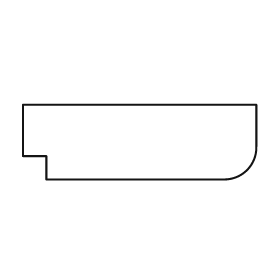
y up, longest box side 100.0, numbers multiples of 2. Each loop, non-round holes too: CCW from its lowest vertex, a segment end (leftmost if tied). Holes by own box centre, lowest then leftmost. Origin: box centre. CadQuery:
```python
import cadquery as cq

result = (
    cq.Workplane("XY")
    .moveTo(-40.0, -16.0)
    .lineTo(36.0, -16.0)
    .threePointArc((46.0, -12.0), (50.0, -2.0))
    .lineTo(50.0, 16.0)
    .lineTo(-50.0, 16.0)
    .lineTo(-50.0, -6.0)
    .lineTo(-40.0, -6.0)
    .close()
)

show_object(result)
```